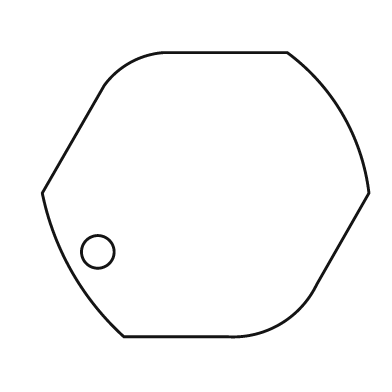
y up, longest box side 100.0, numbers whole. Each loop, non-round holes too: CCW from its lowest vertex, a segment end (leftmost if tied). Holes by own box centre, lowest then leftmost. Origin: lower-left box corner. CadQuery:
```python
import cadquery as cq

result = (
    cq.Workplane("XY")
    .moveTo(25.0, 0.0)
    .lineTo(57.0, 0.0)
    .threePointArc((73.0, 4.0), (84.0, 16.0))
    .lineTo(100.0, 44.0)
    .threePointArc((92.0, 68.0), (75.0, 87.0))
    .lineTo(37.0, 87.0)
    .threePointArc((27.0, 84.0), (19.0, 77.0))
    .lineTo(0.0, 44.0)
    .threePointArc((9.0, 20.0), (25.0, 0.0))
    .close()
    .moveTo(17.0, 26.0)
    .circle(5.0)
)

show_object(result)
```